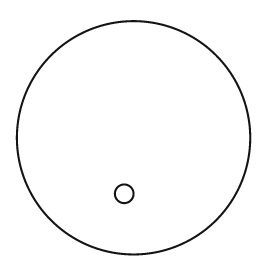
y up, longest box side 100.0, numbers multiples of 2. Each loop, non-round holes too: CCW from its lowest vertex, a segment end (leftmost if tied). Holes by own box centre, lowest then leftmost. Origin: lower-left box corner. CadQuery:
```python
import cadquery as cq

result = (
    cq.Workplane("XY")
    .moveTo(50.0, 50.0)
    .circle(50.0)
    .moveTo(46.0, 26.0)
    .circle(4.0)
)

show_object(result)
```